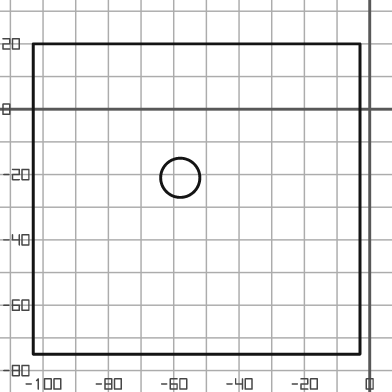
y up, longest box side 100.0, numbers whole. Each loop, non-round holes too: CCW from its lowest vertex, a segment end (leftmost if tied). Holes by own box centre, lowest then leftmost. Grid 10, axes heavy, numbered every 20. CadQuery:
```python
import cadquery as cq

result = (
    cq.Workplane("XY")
    .moveTo(-103.0, -75.0)
    .lineTo(-3.0, -75.0)
    .lineTo(-3.0, 20.0)
    .lineTo(-103.0, 20.0)
    .close()
    .moveTo(-58.0, -21.0)
    .circle(6.0)
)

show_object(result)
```